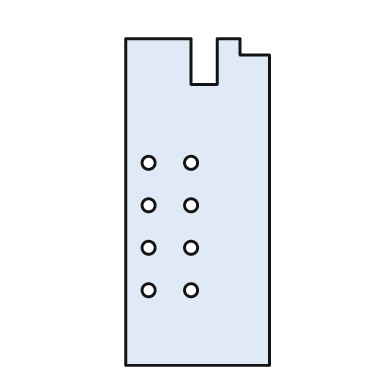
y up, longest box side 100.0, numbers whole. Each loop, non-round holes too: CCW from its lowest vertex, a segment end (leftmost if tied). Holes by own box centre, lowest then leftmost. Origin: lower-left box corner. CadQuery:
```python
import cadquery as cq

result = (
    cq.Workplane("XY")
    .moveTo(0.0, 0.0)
    .lineTo(44.0, 0.0)
    .lineTo(44.0, 95.0)
    .lineTo(35.0, 95.0)
    .lineTo(35.0, 100.0)
    .lineTo(28.0, 100.0)
    .lineTo(28.0, 86.0)
    .lineTo(20.0, 86.0)
    .lineTo(20.0, 100.0)
    .lineTo(0.0, 100.0)
    .close()
    .moveTo(7.0, 23.0)
    .circle(2.0)
    .moveTo(20.0, 23.0)
    .circle(2.0)
    .moveTo(7.0, 36.0)
    .circle(2.0)
    .moveTo(20.0, 36.0)
    .circle(2.0)
    .moveTo(7.0, 49.0)
    .circle(2.0)
    .moveTo(20.0, 49.0)
    .circle(2.0)
    .moveTo(7.0, 62.0)
    .circle(2.0)
    .moveTo(20.0, 62.0)
    .circle(2.0)
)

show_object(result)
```